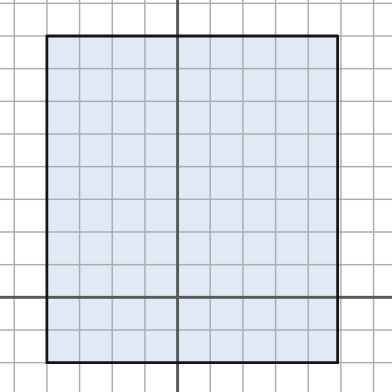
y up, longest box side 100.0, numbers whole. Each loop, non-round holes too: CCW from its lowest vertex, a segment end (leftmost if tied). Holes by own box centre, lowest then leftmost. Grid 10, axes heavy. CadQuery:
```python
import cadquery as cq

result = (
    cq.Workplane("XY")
    .moveTo(-40.0, -20.0)
    .lineTo(49.0, -20.0)
    .lineTo(49.0, 80.0)
    .lineTo(-40.0, 80.0)
    .close()
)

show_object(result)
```